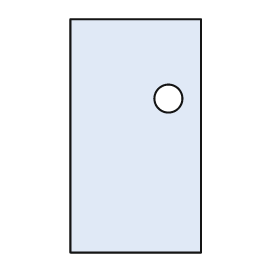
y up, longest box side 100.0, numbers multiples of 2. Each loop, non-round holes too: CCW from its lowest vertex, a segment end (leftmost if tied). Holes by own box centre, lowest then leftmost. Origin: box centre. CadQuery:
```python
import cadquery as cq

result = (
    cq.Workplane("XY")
    .moveTo(-28.0, -50.0)
    .lineTo(28.0, -50.0)
    .lineTo(28.0, 50.0)
    .lineTo(-28.0, 50.0)
    .close()
    .moveTo(14.0, 16.0)
    .circle(6.0)
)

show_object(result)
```